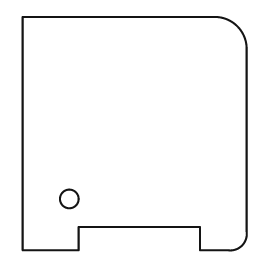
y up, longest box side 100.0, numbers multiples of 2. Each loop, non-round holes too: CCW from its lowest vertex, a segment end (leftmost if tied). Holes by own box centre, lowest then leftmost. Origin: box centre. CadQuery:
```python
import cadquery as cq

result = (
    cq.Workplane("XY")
    .moveTo(-48.0, -50.0)
    .lineTo(-24.0, -50.0)
    .lineTo(-24.0, -40.0)
    .lineTo(28.0, -40.0)
    .lineTo(28.0, -50.0)
    .lineTo(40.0, -50.0)
    .threePointArc((46.0, -48.0), (48.0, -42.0))
    .lineTo(48.0, 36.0)
    .threePointArc((44.0, 46.0), (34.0, 50.0))
    .lineTo(-48.0, 50.0)
    .close()
    .moveTo(-28.0, -28.0)
    .circle(4.0)
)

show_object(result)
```